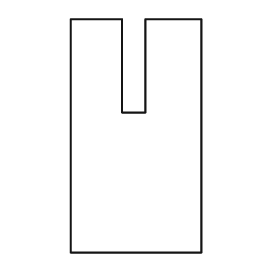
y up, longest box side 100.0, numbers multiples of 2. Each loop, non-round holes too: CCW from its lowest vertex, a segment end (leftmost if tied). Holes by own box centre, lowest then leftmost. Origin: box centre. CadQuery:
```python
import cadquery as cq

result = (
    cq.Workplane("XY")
    .moveTo(-28.0, -50.0)
    .lineTo(28.0, -50.0)
    .lineTo(28.0, 50.0)
    .lineTo(4.0, 50.0)
    .lineTo(4.0, 10.0)
    .lineTo(-6.0, 10.0)
    .lineTo(-6.0, 50.0)
    .lineTo(-28.0, 50.0)
    .close()
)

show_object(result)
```